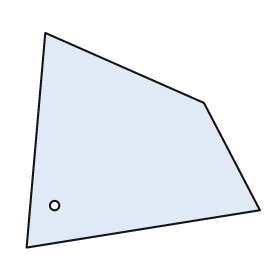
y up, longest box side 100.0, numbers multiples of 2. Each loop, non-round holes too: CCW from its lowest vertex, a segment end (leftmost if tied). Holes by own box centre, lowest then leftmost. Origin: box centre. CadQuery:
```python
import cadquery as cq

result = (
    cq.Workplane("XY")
    .moveTo(-50.0, -46.0)
    .lineTo(50.0, -30.0)
    .lineTo(26.0, 16.0)
    .lineTo(-42.0, 46.0)
    .close()
    .moveTo(-38.0, -28.0)
    .circle(2.0)
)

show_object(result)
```